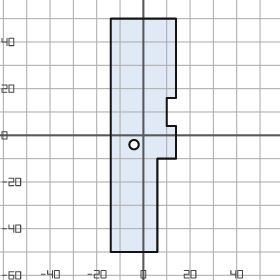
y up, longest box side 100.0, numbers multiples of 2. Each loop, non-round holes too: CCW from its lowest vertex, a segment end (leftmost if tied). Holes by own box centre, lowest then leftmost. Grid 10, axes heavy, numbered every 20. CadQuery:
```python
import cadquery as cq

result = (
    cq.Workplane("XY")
    .moveTo(-14.0, -50.0)
    .lineTo(6.0, -50.0)
    .lineTo(6.0, -10.0)
    .lineTo(14.0, -10.0)
    .lineTo(14.0, 4.0)
    .lineTo(10.0, 4.0)
    .lineTo(10.0, 16.0)
    .lineTo(14.0, 16.0)
    .lineTo(14.0, 50.0)
    .lineTo(-14.0, 50.0)
    .close()
    .moveTo(-4.0, -4.0)
    .circle(2.0)
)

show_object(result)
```